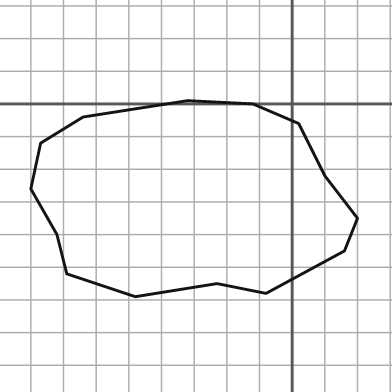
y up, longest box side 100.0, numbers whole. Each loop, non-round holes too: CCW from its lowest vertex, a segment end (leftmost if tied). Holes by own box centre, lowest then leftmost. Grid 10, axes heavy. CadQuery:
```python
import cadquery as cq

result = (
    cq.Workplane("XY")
    .moveTo(-48.0, -59.0)
    .lineTo(-23.0, -55.0)
    .lineTo(-8.0, -58.0)
    .lineTo(16.0, -45.0)
    .lineTo(20.0, -35.0)
    .lineTo(10.0, -22.0)
    .lineTo(2.0, -6.0)
    .lineTo(-12.0, 0.0)
    .lineTo(-32.0, 1.0)
    .lineTo(-64.0, -4.0)
    .lineTo(-77.0, -12.0)
    .lineTo(-80.0, -26.0)
    .lineTo(-72.0, -40.0)
    .lineTo(-69.0, -52.0)
    .close()
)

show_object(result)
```